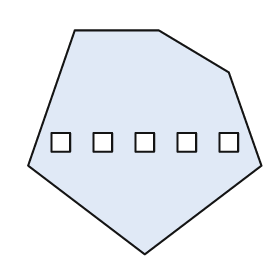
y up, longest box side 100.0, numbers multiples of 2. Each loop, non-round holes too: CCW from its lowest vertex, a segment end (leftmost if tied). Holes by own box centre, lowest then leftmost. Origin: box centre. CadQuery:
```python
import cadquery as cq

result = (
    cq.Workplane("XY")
    .moveTo(0.0, -48.0)
    .lineTo(50.0, -10.0)
    .lineTo(36.0, 30.0)
    .lineTo(6.0, 48.0)
    .lineTo(-30.0, 48.0)
    .lineTo(-50.0, -10.0)
    .close()
    .moveTo(-40.0, -4.0)
    .lineTo(-32.0, -4.0)
    .lineTo(-32.0, 4.0)
    .lineTo(-40.0, 4.0)
    .close()
    .moveTo(-22.0, -4.0)
    .lineTo(-14.0, -4.0)
    .lineTo(-14.0, 4.0)
    .lineTo(-22.0, 4.0)
    .close()
    .moveTo(-4.0, -4.0)
    .lineTo(4.0, -4.0)
    .lineTo(4.0, 4.0)
    .lineTo(-4.0, 4.0)
    .close()
    .moveTo(14.0, -4.0)
    .lineTo(22.0, -4.0)
    .lineTo(22.0, 4.0)
    .lineTo(14.0, 4.0)
    .close()
    .moveTo(32.0, -4.0)
    .lineTo(40.0, -4.0)
    .lineTo(40.0, 4.0)
    .lineTo(32.0, 4.0)
    .close()
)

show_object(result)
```